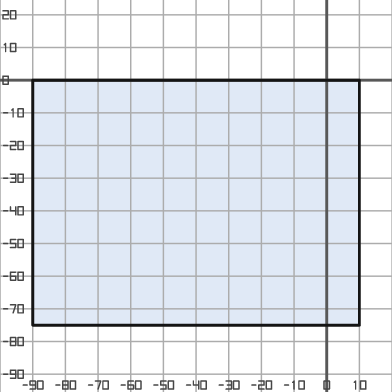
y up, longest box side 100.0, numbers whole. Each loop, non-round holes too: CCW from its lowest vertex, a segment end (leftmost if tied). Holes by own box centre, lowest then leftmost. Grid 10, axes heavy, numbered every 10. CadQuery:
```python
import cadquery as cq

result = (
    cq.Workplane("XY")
    .moveTo(-90.0, -75.0)
    .lineTo(10.0, -75.0)
    .lineTo(10.0, 0.0)
    .lineTo(-90.0, 0.0)
    .close()
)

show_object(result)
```